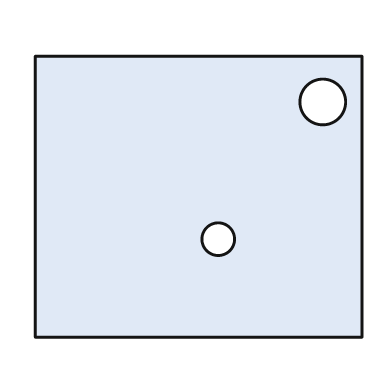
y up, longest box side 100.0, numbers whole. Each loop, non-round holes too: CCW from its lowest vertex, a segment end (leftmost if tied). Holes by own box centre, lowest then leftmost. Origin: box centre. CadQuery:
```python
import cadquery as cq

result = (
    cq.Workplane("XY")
    .moveTo(-50.0, -43.0)
    .lineTo(50.0, -43.0)
    .lineTo(50.0, 43.0)
    .lineTo(-50.0, 43.0)
    .close()
    .moveTo(6.0, -13.0)
    .circle(5.0)
    .moveTo(38.0, 29.0)
    .circle(7.0)
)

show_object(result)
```